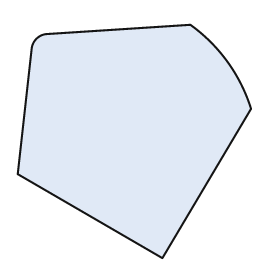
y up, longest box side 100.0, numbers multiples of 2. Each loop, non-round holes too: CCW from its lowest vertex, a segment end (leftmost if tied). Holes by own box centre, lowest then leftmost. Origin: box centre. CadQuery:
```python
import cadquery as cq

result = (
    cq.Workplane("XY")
    .moveTo(12.0, -50.0)
    .lineTo(50.0, 14.0)
    .threePointArc((40.0, 34.0), (24.0, 50.0))
    .lineTo(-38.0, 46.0)
    .threePointArc((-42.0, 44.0), (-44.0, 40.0))
    .lineTo(-50.0, -14.0)
    .close()
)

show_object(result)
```